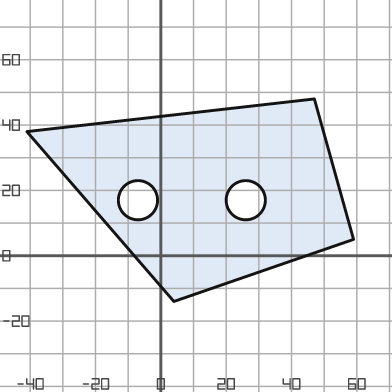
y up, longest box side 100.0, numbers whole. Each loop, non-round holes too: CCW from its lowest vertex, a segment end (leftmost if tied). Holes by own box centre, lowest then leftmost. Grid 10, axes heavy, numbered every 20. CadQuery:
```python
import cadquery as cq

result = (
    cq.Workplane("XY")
    .moveTo(4.0, -14.0)
    .lineTo(59.0, 5.0)
    .lineTo(47.0, 48.0)
    .lineTo(-41.0, 38.0)
    .close()
    .moveTo(-7.0, 17.0)
    .circle(6.0)
    .moveTo(26.0, 17.0)
    .circle(6.0)
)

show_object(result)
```